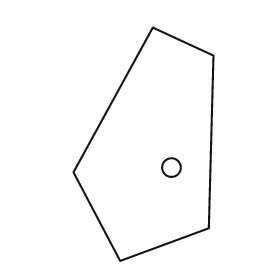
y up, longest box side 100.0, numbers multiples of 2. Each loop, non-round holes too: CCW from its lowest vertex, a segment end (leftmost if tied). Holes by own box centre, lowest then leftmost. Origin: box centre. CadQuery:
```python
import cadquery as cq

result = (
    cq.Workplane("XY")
    .moveTo(-10.0, -50.0)
    .lineTo(28.0, -36.0)
    .lineTo(30.0, 38.0)
    .lineTo(4.0, 50.0)
    .lineTo(-30.0, -12.0)
    .close()
    .moveTo(12.0, -10.0)
    .circle(4.0)
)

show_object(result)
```